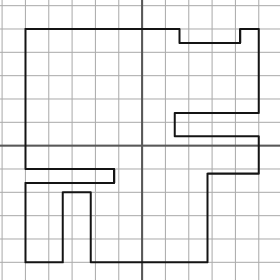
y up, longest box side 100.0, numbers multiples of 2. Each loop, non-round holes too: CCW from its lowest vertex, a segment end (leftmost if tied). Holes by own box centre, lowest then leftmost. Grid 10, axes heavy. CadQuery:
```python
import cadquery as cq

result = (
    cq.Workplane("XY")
    .moveTo(-50.0, -50.0)
    .lineTo(-34.0, -50.0)
    .lineTo(-34.0, -20.0)
    .lineTo(-22.0, -20.0)
    .lineTo(-22.0, -50.0)
    .lineTo(28.0, -50.0)
    .lineTo(28.0, -12.0)
    .lineTo(50.0, -12.0)
    .lineTo(50.0, 4.0)
    .lineTo(14.0, 4.0)
    .lineTo(14.0, 14.0)
    .lineTo(50.0, 14.0)
    .lineTo(50.0, 50.0)
    .lineTo(42.0, 50.0)
    .lineTo(42.0, 44.0)
    .lineTo(16.0, 44.0)
    .lineTo(16.0, 50.0)
    .lineTo(-50.0, 50.0)
    .lineTo(-50.0, -10.0)
    .lineTo(-12.0, -10.0)
    .lineTo(-12.0, -16.0)
    .lineTo(-50.0, -16.0)
    .close()
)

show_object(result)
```